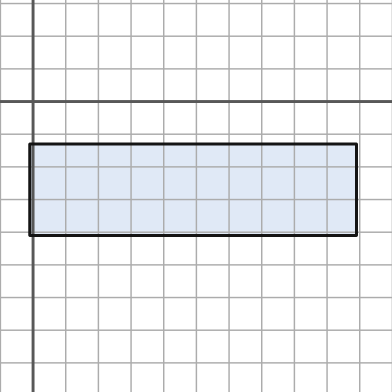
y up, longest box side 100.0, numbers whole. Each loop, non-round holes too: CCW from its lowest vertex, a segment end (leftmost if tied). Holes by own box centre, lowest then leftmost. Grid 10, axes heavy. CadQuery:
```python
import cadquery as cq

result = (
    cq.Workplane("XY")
    .moveTo(-1.0, -41.0)
    .lineTo(99.0, -41.0)
    .lineTo(99.0, -13.0)
    .lineTo(-1.0, -13.0)
    .close()
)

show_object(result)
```